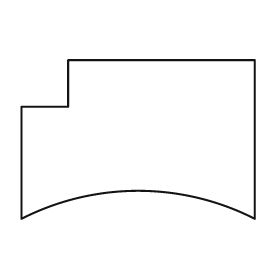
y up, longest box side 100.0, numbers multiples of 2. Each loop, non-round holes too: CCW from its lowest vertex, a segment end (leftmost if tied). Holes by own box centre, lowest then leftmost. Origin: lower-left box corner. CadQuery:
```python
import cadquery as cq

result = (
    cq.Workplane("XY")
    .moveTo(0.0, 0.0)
    .threePointArc((50.0, 12.0), (100.0, 0.0))
    .lineTo(100.0, 68.0)
    .lineTo(20.0, 68.0)
    .lineTo(20.0, 48.0)
    .lineTo(0.0, 48.0)
    .close()
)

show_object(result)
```